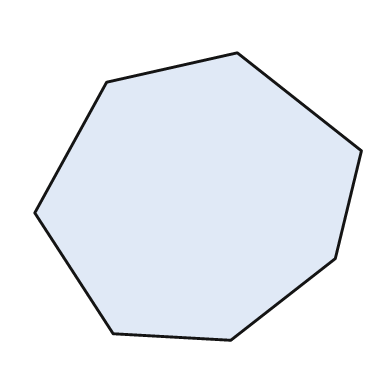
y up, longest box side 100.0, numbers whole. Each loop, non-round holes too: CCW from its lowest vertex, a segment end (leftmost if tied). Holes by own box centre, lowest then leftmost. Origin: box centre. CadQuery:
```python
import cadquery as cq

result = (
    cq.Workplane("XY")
    .moveTo(10.0, -44.0)
    .lineTo(42.0, -19.0)
    .lineTo(50.0, 14.0)
    .lineTo(12.0, 44.0)
    .lineTo(-28.0, 35.0)
    .lineTo(-50.0, -5.0)
    .lineTo(-26.0, -42.0)
    .close()
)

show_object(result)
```